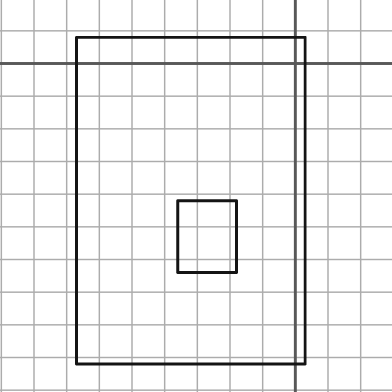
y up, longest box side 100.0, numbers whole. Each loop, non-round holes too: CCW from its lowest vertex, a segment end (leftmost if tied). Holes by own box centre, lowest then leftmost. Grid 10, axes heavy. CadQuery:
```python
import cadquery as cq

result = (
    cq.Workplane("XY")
    .moveTo(-67.0, -92.0)
    .lineTo(3.0, -92.0)
    .lineTo(3.0, 8.0)
    .lineTo(-67.0, 8.0)
    .close()
    .moveTo(-36.0, -64.0)
    .lineTo(-18.0, -64.0)
    .lineTo(-18.0, -42.0)
    .lineTo(-36.0, -42.0)
    .close()
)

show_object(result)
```